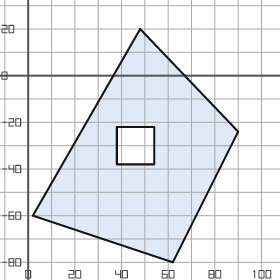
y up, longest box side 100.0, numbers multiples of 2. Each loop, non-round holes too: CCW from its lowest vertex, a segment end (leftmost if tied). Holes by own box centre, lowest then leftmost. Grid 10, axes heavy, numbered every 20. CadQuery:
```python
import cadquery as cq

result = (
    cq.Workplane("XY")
    .moveTo(62.0, -80.0)
    .lineTo(90.0, -24.0)
    .lineTo(48.0, 20.0)
    .lineTo(2.0, -60.0)
    .close()
    .moveTo(38.0, -38.0)
    .lineTo(54.0, -38.0)
    .lineTo(54.0, -22.0)
    .lineTo(38.0, -22.0)
    .close()
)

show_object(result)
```